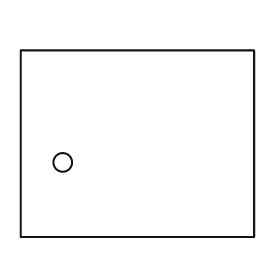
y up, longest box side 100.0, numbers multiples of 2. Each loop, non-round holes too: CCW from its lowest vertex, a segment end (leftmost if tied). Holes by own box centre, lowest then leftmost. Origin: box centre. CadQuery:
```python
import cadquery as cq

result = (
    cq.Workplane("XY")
    .moveTo(-50.0, -40.0)
    .lineTo(50.0, -40.0)
    .lineTo(50.0, 40.0)
    .lineTo(-50.0, 40.0)
    .close()
    .moveTo(-32.0, -8.0)
    .circle(4.0)
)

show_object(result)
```